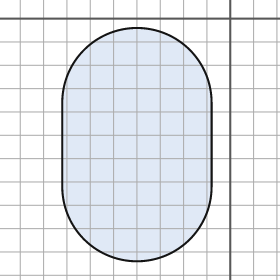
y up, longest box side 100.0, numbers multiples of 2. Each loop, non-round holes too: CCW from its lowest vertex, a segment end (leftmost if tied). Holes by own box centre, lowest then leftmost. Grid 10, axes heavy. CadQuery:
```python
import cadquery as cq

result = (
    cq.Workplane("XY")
    .moveTo(-72.0, -72.0)
    .threePointArc((-40.0, -104.0), (-8.0, -72.0))
    .lineTo(-8.0, -36.0)
    .threePointArc((-40.0, -4.0), (-72.0, -36.0))
    .close()
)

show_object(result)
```